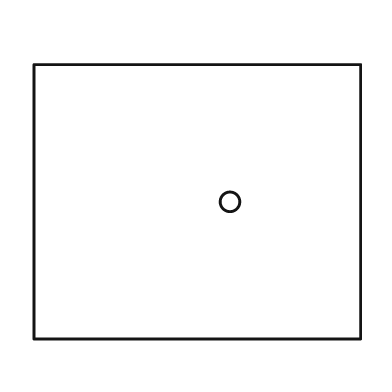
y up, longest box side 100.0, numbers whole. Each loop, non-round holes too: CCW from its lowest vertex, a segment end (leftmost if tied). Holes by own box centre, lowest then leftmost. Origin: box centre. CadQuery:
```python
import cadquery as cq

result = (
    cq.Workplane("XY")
    .moveTo(-50.0, -42.0)
    .lineTo(50.0, -42.0)
    .lineTo(50.0, 42.0)
    .lineTo(-50.0, 42.0)
    .close()
    .moveTo(10.0, 0.0)
    .circle(3.0)
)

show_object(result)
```